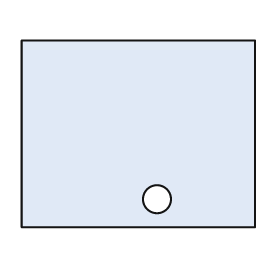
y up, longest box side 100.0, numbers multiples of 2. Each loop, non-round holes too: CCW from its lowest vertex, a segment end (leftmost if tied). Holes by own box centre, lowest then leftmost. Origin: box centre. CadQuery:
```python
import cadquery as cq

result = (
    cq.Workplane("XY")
    .moveTo(-50.0, -40.0)
    .lineTo(50.0, -40.0)
    .lineTo(50.0, 40.0)
    .lineTo(-50.0, 40.0)
    .close()
    .moveTo(8.0, -28.0)
    .circle(6.0)
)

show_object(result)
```